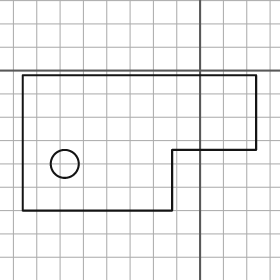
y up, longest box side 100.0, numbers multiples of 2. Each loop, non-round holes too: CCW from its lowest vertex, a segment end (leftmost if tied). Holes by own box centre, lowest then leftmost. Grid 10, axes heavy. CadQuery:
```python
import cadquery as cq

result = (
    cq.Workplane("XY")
    .moveTo(-76.0, -60.0)
    .lineTo(-12.0, -60.0)
    .lineTo(-12.0, -34.0)
    .lineTo(24.0, -34.0)
    .lineTo(24.0, -2.0)
    .lineTo(-76.0, -2.0)
    .close()
    .moveTo(-58.0, -40.0)
    .circle(6.0)
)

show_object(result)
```